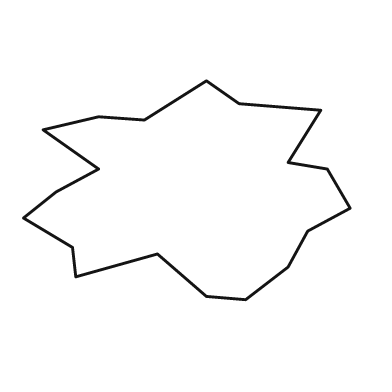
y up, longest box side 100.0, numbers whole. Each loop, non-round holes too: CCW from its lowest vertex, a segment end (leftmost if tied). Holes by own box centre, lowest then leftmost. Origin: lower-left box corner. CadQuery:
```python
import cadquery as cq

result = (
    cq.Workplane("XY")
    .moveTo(68.0, 0.0)
    .lineTo(81.0, 10.0)
    .lineTo(87.0, 21.0)
    .lineTo(100.0, 28.0)
    .lineTo(93.0, 40.0)
    .lineTo(81.0, 42.0)
    .lineTo(91.0, 58.0)
    .lineTo(66.0, 60.0)
    .lineTo(56.0, 67.0)
    .lineTo(37.0, 55.0)
    .lineTo(23.0, 56.0)
    .lineTo(6.0, 52.0)
    .lineTo(23.0, 40.0)
    .lineTo(10.0, 33.0)
    .lineTo(0.0, 25.0)
    .lineTo(15.0, 16.0)
    .lineTo(16.0, 7.0)
    .lineTo(41.0, 14.0)
    .lineTo(56.0, 1.0)
    .close()
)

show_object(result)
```